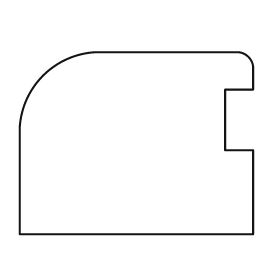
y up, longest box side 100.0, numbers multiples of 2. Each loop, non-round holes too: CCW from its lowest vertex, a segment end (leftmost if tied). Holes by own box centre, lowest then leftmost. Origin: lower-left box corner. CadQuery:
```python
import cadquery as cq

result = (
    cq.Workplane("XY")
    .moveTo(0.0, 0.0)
    .lineTo(100.0, 0.0)
    .lineTo(100.0, 36.0)
    .lineTo(88.0, 36.0)
    .lineTo(88.0, 62.0)
    .lineTo(100.0, 62.0)
    .lineTo(100.0, 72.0)
    .threePointArc((98.0, 76.0), (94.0, 78.0))
    .lineTo(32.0, 78.0)
    .threePointArc((10.0, 68.0), (0.0, 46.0))
    .close()
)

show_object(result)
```